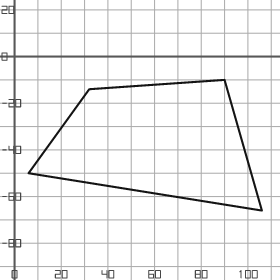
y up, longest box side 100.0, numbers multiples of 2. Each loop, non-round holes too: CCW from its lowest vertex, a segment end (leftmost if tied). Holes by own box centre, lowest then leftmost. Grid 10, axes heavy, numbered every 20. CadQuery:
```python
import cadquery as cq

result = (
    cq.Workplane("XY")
    .moveTo(106.0, -66.0)
    .lineTo(90.0, -10.0)
    .lineTo(32.0, -14.0)
    .lineTo(6.0, -50.0)
    .close()
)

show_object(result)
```